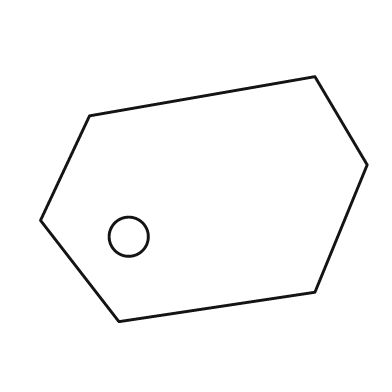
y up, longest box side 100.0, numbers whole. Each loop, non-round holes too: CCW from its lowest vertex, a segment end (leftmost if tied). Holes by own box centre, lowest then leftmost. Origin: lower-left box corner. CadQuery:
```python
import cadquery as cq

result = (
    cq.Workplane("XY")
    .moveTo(24.0, 0.0)
    .lineTo(84.0, 9.0)
    .lineTo(100.0, 48.0)
    .lineTo(84.0, 75.0)
    .lineTo(15.0, 63.0)
    .lineTo(0.0, 31.0)
    .close()
    .moveTo(27.0, 26.0)
    .circle(6.0)
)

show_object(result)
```